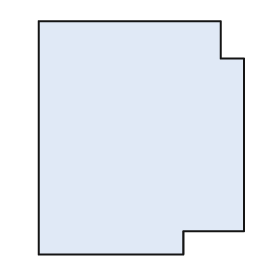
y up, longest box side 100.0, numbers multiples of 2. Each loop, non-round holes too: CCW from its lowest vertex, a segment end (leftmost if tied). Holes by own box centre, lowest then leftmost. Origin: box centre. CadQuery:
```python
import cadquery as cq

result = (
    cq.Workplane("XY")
    .moveTo(-44.0, -50.0)
    .lineTo(18.0, -50.0)
    .lineTo(18.0, -40.0)
    .lineTo(44.0, -40.0)
    .lineTo(44.0, 34.0)
    .lineTo(34.0, 34.0)
    .lineTo(34.0, 50.0)
    .lineTo(-44.0, 50.0)
    .close()
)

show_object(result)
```